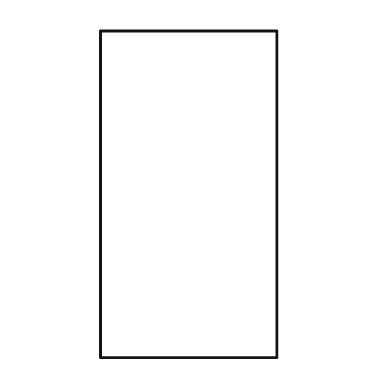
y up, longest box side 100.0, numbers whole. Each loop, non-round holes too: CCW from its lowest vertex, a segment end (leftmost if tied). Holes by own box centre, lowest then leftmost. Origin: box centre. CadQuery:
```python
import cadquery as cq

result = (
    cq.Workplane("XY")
    .moveTo(-27.0, -50.0)
    .lineTo(27.0, -50.0)
    .lineTo(27.0, 50.0)
    .lineTo(-27.0, 50.0)
    .close()
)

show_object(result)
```